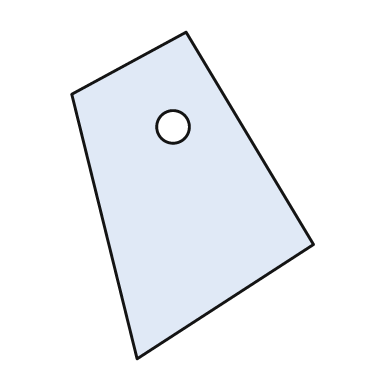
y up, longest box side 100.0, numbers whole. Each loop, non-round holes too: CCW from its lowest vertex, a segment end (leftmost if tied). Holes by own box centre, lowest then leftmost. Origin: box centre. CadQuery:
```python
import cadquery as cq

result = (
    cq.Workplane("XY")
    .moveTo(-17.0, -50.0)
    .lineTo(37.0, -15.0)
    .lineTo(-2.0, 50.0)
    .lineTo(-37.0, 31.0)
    .close()
    .moveTo(-6.0, 21.0)
    .circle(5.0)
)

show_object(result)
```